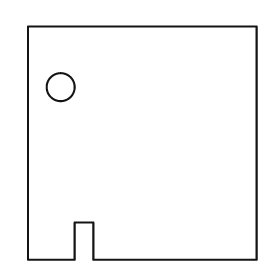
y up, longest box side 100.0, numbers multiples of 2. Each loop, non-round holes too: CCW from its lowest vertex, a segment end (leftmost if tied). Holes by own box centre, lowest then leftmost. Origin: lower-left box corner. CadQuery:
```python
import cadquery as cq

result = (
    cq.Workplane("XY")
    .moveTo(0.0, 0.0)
    .lineTo(20.0, 0.0)
    .lineTo(20.0, 16.0)
    .lineTo(28.0, 16.0)
    .lineTo(28.0, 0.0)
    .lineTo(98.0, 0.0)
    .lineTo(98.0, 100.0)
    .lineTo(0.0, 100.0)
    .close()
    .moveTo(14.0, 74.0)
    .circle(6.0)
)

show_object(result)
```